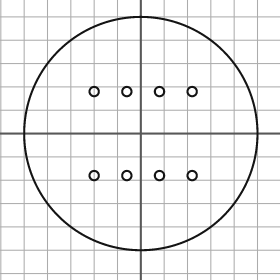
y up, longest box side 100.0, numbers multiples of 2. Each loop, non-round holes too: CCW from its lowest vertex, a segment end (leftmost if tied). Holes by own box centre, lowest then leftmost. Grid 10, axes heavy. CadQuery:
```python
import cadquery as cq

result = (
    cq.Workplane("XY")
    .moveTo(0.0, 0.0)
    .circle(50.0)
    .moveTo(-20.0, -18.0)
    .circle(2.0)
    .moveTo(-6.0, -18.0)
    .circle(2.0)
    .moveTo(8.0, -18.0)
    .circle(2.0)
    .moveTo(22.0, -18.0)
    .circle(2.0)
    .moveTo(-20.0, 18.0)
    .circle(2.0)
    .moveTo(-6.0, 18.0)
    .circle(2.0)
    .moveTo(8.0, 18.0)
    .circle(2.0)
    .moveTo(22.0, 18.0)
    .circle(2.0)
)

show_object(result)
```